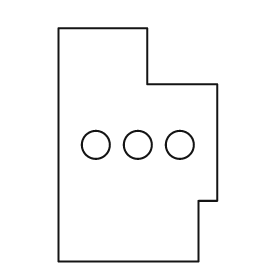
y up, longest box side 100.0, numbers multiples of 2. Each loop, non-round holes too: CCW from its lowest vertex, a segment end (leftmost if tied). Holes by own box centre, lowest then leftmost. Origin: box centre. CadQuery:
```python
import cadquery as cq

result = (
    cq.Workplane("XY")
    .moveTo(-34.0, -50.0)
    .lineTo(26.0, -50.0)
    .lineTo(26.0, -24.0)
    .lineTo(34.0, -24.0)
    .lineTo(34.0, 26.0)
    .lineTo(4.0, 26.0)
    .lineTo(4.0, 50.0)
    .lineTo(-34.0, 50.0)
    .close()
    .moveTo(-18.0, 0.0)
    .circle(6.0)
    .moveTo(0.0, 0.0)
    .circle(6.0)
    .moveTo(18.0, 0.0)
    .circle(6.0)
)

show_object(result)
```